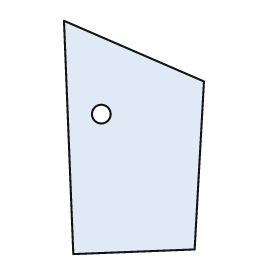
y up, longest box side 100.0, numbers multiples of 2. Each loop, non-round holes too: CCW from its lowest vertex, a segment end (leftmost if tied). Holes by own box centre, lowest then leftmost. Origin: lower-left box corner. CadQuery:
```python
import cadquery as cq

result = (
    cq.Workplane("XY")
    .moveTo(4.0, 0.0)
    .lineTo(56.0, 2.0)
    .lineTo(60.0, 74.0)
    .lineTo(0.0, 100.0)
    .close()
    .moveTo(16.0, 60.0)
    .circle(4.0)
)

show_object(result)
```